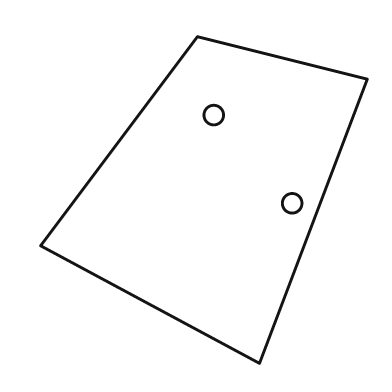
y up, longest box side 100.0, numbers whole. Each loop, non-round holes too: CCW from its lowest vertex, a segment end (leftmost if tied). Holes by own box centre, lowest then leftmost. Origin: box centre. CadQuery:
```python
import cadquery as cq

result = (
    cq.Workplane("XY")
    .moveTo(17.0, -50.0)
    .lineTo(50.0, 37.0)
    .lineTo(-2.0, 50.0)
    .lineTo(-50.0, -14.0)
    .close()
    .moveTo(27.0, -1.0)
    .circle(3.0)
    .moveTo(3.0, 26.0)
    .circle(3.0)
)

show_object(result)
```